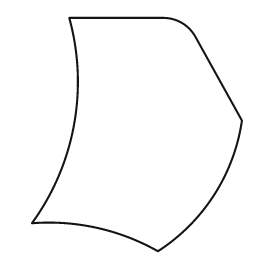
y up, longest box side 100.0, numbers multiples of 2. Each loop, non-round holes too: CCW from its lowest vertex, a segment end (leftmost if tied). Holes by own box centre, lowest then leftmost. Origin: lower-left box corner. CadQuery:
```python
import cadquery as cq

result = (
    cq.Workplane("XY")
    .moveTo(54.0, 0.0)
    .threePointArc((78.0, 24.0), (90.0, 56.0))
    .lineTo(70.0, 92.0)
    .threePointArc((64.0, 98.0), (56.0, 100.0))
    .lineTo(16.0, 100.0)
    .threePointArc((18.0, 54.0), (0.0, 12.0))
    .threePointArc((28.0, 10.0), (54.0, 0.0))
    .close()
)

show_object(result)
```